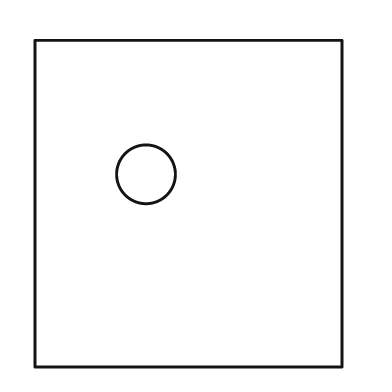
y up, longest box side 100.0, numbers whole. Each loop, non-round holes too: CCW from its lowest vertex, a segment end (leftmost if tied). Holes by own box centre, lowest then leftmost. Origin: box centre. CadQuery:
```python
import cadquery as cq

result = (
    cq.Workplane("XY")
    .moveTo(-47.0, -50.0)
    .lineTo(47.0, -50.0)
    .lineTo(47.0, 50.0)
    .lineTo(-47.0, 50.0)
    .close()
    .moveTo(-13.0, 9.0)
    .circle(9.0)
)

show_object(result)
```